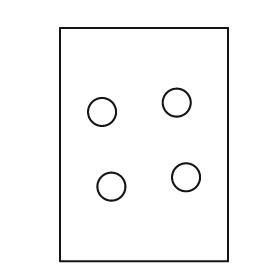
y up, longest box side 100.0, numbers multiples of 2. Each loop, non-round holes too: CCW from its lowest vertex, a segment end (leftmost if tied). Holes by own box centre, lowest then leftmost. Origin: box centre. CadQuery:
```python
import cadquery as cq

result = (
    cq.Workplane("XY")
    .moveTo(-36.0, -50.0)
    .lineTo(36.0, -50.0)
    .lineTo(36.0, 50.0)
    .lineTo(-36.0, 50.0)
    .close()
    .moveTo(-14.0, -18.0)
    .circle(6.0)
    .moveTo(18.0, -14.0)
    .circle(6.0)
    .moveTo(-18.0, 14.0)
    .circle(6.0)
    .moveTo(14.0, 18.0)
    .circle(6.0)
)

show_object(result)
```